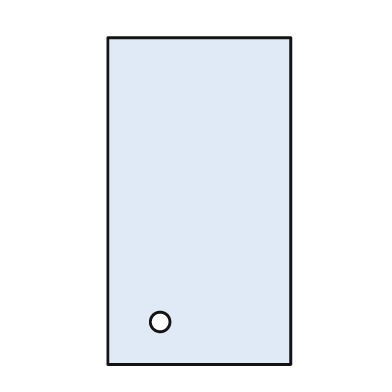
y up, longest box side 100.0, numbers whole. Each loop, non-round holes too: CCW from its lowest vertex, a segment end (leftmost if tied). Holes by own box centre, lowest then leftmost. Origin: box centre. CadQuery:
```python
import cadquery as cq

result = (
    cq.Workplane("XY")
    .moveTo(-28.0, -50.0)
    .lineTo(28.0, -50.0)
    .lineTo(28.0, 50.0)
    .lineTo(-28.0, 50.0)
    .close()
    .moveTo(-12.0, -37.0)
    .circle(3.0)
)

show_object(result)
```